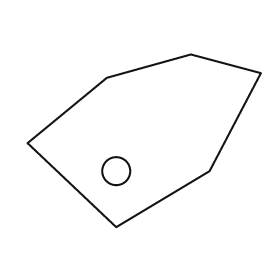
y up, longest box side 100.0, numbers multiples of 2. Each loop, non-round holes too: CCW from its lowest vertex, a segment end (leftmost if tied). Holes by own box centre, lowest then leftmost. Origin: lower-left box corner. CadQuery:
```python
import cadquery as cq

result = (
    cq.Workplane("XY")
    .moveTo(38.0, 0.0)
    .lineTo(78.0, 24.0)
    .lineTo(100.0, 66.0)
    .lineTo(70.0, 74.0)
    .lineTo(34.0, 64.0)
    .lineTo(0.0, 36.0)
    .close()
    .moveTo(38.0, 24.0)
    .circle(6.0)
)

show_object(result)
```